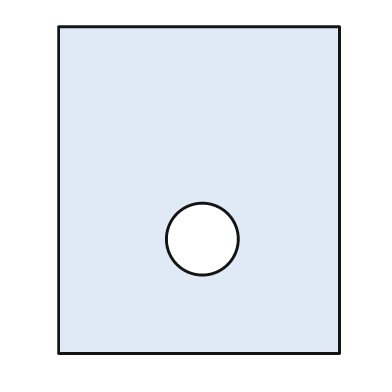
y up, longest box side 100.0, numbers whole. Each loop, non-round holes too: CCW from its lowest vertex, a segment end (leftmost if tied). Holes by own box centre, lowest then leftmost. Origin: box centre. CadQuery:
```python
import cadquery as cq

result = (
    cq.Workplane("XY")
    .moveTo(-43.0, -50.0)
    .lineTo(43.0, -50.0)
    .lineTo(43.0, 50.0)
    .lineTo(-43.0, 50.0)
    .close()
    .moveTo(1.0, -15.0)
    .circle(11.0)
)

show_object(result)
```